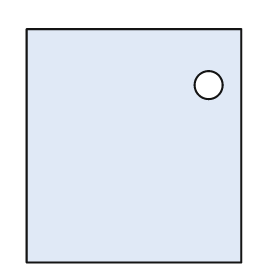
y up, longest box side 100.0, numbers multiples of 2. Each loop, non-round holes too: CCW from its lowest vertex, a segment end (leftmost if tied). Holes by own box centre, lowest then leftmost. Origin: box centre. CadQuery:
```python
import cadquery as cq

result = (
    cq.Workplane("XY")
    .moveTo(-46.0, -50.0)
    .lineTo(46.0, -50.0)
    .lineTo(46.0, 50.0)
    .lineTo(-46.0, 50.0)
    .close()
    .moveTo(32.0, 26.0)
    .circle(6.0)
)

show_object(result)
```